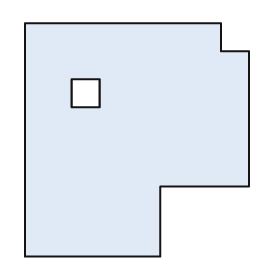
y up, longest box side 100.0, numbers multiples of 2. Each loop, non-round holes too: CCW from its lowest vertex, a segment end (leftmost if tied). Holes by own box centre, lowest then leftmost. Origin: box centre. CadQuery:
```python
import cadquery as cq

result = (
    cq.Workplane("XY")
    .moveTo(-48.0, -50.0)
    .lineTo(10.0, -50.0)
    .lineTo(10.0, -20.0)
    .lineTo(48.0, -20.0)
    .lineTo(48.0, 38.0)
    .lineTo(36.0, 38.0)
    .lineTo(36.0, 50.0)
    .lineTo(-48.0, 50.0)
    .close()
    .moveTo(-28.0, 14.0)
    .lineTo(-16.0, 14.0)
    .lineTo(-16.0, 26.0)
    .lineTo(-28.0, 26.0)
    .close()
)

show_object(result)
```